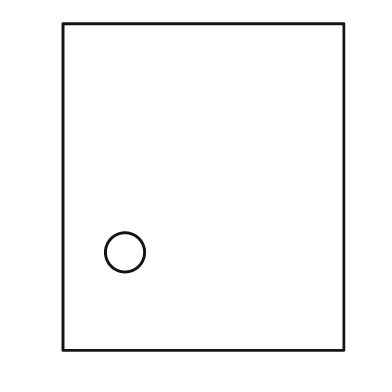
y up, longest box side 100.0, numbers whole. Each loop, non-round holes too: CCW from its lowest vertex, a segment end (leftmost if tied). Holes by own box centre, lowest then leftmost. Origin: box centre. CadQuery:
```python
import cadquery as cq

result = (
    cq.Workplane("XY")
    .moveTo(-43.0, -50.0)
    .lineTo(43.0, -50.0)
    .lineTo(43.0, 50.0)
    .lineTo(-43.0, 50.0)
    .close()
    .moveTo(-24.0, -20.0)
    .circle(6.0)
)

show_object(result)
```